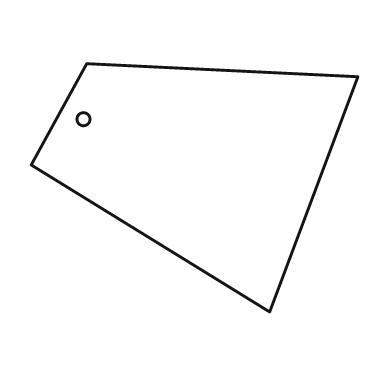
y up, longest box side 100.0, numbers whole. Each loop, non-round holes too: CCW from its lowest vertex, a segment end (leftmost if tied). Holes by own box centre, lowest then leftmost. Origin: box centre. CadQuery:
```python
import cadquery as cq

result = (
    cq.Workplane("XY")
    .moveTo(23.0, -38.0)
    .lineTo(50.0, 34.0)
    .lineTo(-33.0, 38.0)
    .lineTo(-50.0, 7.0)
    .close()
    .moveTo(-34.0, 21.0)
    .circle(2.0)
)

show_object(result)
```